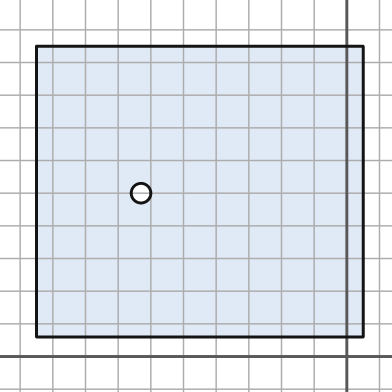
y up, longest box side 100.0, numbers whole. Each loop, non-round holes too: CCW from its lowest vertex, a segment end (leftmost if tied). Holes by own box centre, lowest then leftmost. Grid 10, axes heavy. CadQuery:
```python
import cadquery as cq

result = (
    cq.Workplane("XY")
    .moveTo(-95.0, 6.0)
    .lineTo(5.0, 6.0)
    .lineTo(5.0, 95.0)
    .lineTo(-95.0, 95.0)
    .close()
    .moveTo(-63.0, 50.0)
    .circle(3.0)
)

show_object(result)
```